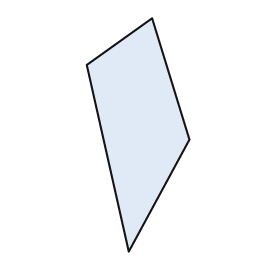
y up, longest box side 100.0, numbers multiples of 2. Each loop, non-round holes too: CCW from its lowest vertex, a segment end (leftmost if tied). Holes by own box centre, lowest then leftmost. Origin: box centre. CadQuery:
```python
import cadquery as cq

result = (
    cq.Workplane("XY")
    .moveTo(-4.0, -50.0)
    .lineTo(22.0, -2.0)
    .lineTo(6.0, 50.0)
    .lineTo(-22.0, 30.0)
    .close()
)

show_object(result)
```